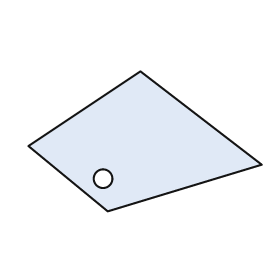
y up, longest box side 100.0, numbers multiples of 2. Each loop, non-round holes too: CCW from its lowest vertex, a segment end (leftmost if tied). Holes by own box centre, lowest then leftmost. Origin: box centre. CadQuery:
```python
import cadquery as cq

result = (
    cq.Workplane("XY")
    .moveTo(-16.0, -30.0)
    .lineTo(50.0, -10.0)
    .lineTo(-2.0, 30.0)
    .lineTo(-50.0, -2.0)
    .close()
    .moveTo(-18.0, -16.0)
    .circle(4.0)
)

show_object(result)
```